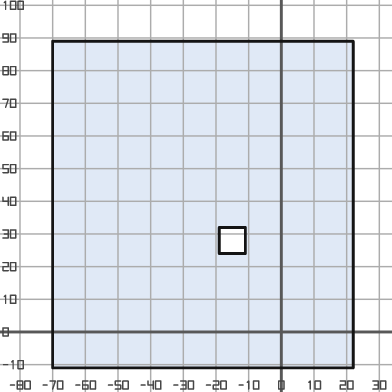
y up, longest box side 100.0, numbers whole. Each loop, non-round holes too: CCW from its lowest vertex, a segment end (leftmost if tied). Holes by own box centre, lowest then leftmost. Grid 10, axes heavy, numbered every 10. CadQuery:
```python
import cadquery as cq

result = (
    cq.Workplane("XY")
    .moveTo(-70.0, -11.0)
    .lineTo(22.0, -11.0)
    .lineTo(22.0, 89.0)
    .lineTo(-70.0, 89.0)
    .close()
    .moveTo(-19.0, 24.0)
    .lineTo(-11.0, 24.0)
    .lineTo(-11.0, 32.0)
    .lineTo(-19.0, 32.0)
    .close()
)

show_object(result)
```